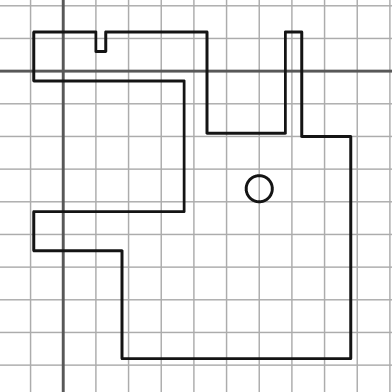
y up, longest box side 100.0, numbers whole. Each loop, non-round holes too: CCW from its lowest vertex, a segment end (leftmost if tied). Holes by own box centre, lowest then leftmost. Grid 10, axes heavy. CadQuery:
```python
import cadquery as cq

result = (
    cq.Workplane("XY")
    .moveTo(18.0, -88.0)
    .lineTo(88.0, -88.0)
    .lineTo(88.0, -20.0)
    .lineTo(73.0, -20.0)
    .lineTo(73.0, 12.0)
    .lineTo(68.0, 12.0)
    .lineTo(68.0, -19.0)
    .lineTo(44.0, -19.0)
    .lineTo(44.0, 12.0)
    .lineTo(13.0, 12.0)
    .lineTo(13.0, 6.0)
    .lineTo(10.0, 6.0)
    .lineTo(10.0, 12.0)
    .lineTo(-9.0, 12.0)
    .lineTo(-9.0, -3.0)
    .lineTo(37.0, -3.0)
    .lineTo(37.0, -43.0)
    .lineTo(-9.0, -43.0)
    .lineTo(-9.0, -55.0)
    .lineTo(18.0, -55.0)
    .close()
    .moveTo(60.0, -36.0)
    .circle(4.0)
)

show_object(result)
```